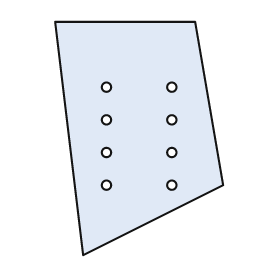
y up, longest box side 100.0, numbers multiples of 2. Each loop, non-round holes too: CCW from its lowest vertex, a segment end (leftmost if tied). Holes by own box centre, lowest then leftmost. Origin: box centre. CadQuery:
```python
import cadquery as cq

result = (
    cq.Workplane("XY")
    .moveTo(-24.0, -50.0)
    .lineTo(36.0, -20.0)
    .lineTo(24.0, 50.0)
    .lineTo(-36.0, 50.0)
    .close()
    .moveTo(-14.0, -20.0)
    .circle(2.0)
    .moveTo(14.0, -20.0)
    .circle(2.0)
    .moveTo(-14.0, -6.0)
    .circle(2.0)
    .moveTo(14.0, -6.0)
    .circle(2.0)
    .moveTo(-14.0, 8.0)
    .circle(2.0)
    .moveTo(14.0, 8.0)
    .circle(2.0)
    .moveTo(-14.0, 22.0)
    .circle(2.0)
    .moveTo(14.0, 22.0)
    .circle(2.0)
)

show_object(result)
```